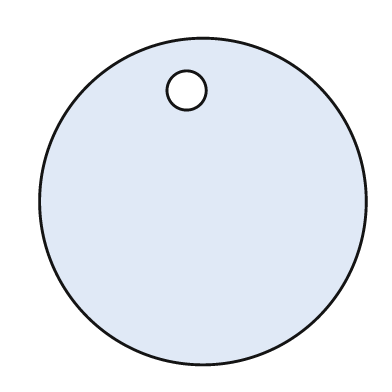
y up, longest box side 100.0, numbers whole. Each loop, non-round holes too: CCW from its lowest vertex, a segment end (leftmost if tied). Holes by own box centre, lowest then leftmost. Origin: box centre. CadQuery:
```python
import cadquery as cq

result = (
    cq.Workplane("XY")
    .moveTo(0.0, 0.0)
    .circle(50.0)
    .moveTo(-5.0, 34.0)
    .circle(6.0)
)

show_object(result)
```